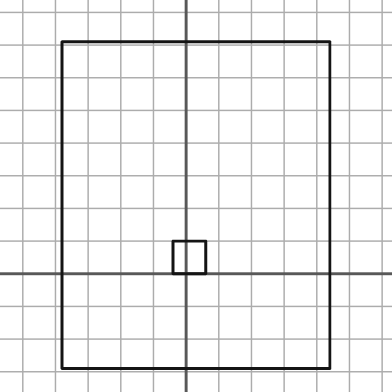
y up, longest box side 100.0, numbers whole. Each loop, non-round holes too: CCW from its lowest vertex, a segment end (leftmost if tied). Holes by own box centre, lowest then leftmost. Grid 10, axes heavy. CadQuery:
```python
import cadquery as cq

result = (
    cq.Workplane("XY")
    .moveTo(-38.0, -29.0)
    .lineTo(44.0, -29.0)
    .lineTo(44.0, 71.0)
    .lineTo(-38.0, 71.0)
    .close()
    .moveTo(-4.0, 0.0)
    .lineTo(6.0, 0.0)
    .lineTo(6.0, 10.0)
    .lineTo(-4.0, 10.0)
    .close()
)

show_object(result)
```